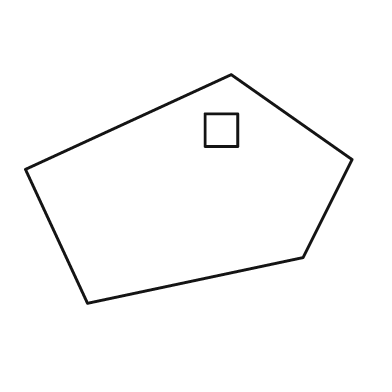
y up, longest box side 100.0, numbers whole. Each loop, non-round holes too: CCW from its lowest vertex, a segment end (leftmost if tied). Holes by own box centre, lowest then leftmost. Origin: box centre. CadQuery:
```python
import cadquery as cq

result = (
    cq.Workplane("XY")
    .moveTo(-31.0, -35.0)
    .lineTo(35.0, -21.0)
    .lineTo(50.0, 9.0)
    .lineTo(13.0, 35.0)
    .lineTo(-50.0, 6.0)
    .close()
    .moveTo(5.0, 13.0)
    .lineTo(15.0, 13.0)
    .lineTo(15.0, 23.0)
    .lineTo(5.0, 23.0)
    .close()
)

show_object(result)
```